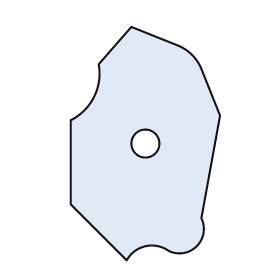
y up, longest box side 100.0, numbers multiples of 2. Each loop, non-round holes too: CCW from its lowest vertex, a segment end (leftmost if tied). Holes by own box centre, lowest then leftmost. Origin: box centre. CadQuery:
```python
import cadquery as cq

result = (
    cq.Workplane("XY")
    .moveTo(-8.0, -50.0)
    .threePointArc((0.0, -44.0), (10.0, -46.0))
    .threePointArc((22.0, -44.0), (24.0, -32.0))
    .lineTo(32.0, 12.0)
    .lineTo(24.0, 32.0)
    .threePointArc((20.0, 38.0), (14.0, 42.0))
    .lineTo(-6.0, 50.0)
    .lineTo(-20.0, 34.0)
    .threePointArc((-22.0, 20.0), (-32.0, 10.0))
    .lineTo(-32.0, -26.0)
    .close()
    .moveTo(0.0, 0.0)
    .circle(6.0)
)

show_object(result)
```